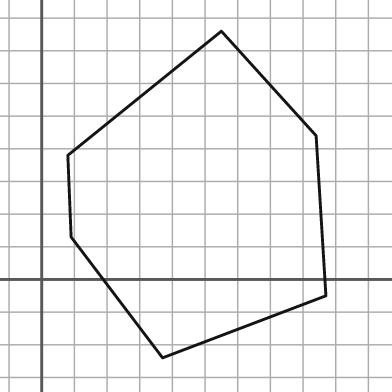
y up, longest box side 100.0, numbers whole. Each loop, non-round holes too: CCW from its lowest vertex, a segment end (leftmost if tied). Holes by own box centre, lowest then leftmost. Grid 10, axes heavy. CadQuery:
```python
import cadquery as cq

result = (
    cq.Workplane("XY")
    .moveTo(37.0, -24.0)
    .lineTo(87.0, -5.0)
    .lineTo(84.0, 44.0)
    .lineTo(55.0, 76.0)
    .lineTo(8.0, 38.0)
    .lineTo(9.0, 13.0)
    .close()
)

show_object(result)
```